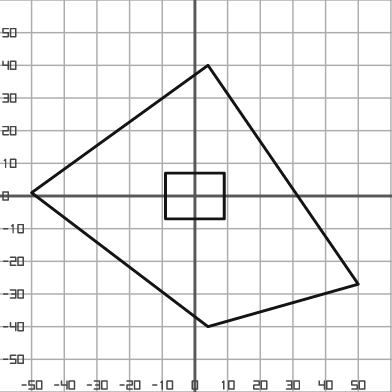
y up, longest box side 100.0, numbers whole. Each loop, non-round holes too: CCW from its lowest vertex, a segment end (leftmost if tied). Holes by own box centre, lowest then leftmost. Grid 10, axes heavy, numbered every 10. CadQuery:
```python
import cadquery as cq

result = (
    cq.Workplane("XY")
    .moveTo(4.0, -40.0)
    .lineTo(50.0, -27.0)
    .lineTo(4.0, 40.0)
    .lineTo(-50.0, 1.0)
    .close()
    .moveTo(-9.0, -7.0)
    .lineTo(9.0, -7.0)
    .lineTo(9.0, 7.0)
    .lineTo(-9.0, 7.0)
    .close()
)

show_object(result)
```